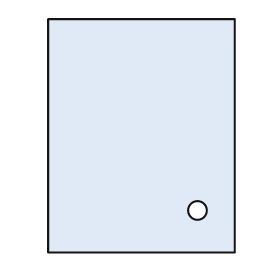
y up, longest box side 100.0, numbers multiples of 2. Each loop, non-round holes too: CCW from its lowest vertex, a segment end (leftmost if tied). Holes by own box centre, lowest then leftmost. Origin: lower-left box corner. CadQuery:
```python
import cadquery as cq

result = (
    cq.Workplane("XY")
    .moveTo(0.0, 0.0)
    .lineTo(80.0, 0.0)
    .lineTo(80.0, 100.0)
    .lineTo(0.0, 100.0)
    .close()
    .moveTo(64.0, 18.0)
    .circle(4.0)
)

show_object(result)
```